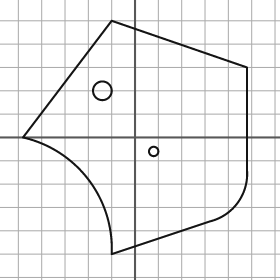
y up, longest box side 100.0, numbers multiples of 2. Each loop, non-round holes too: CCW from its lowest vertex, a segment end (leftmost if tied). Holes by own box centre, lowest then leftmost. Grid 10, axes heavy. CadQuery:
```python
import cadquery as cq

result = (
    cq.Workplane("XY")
    .moveTo(-10.0, -50.0)
    .lineTo(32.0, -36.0)
    .threePointArc((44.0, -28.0), (48.0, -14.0))
    .lineTo(48.0, 30.0)
    .lineTo(-10.0, 50.0)
    .lineTo(-48.0, 0.0)
    .threePointArc((-20.0, -18.0), (-10.0, -50.0))
    .close()
    .moveTo(8.0, -6.0)
    .circle(2.0)
    .moveTo(-14.0, 20.0)
    .circle(4.0)
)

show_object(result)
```